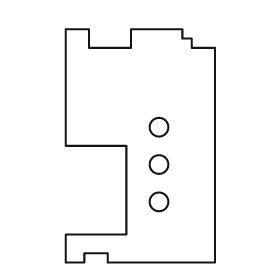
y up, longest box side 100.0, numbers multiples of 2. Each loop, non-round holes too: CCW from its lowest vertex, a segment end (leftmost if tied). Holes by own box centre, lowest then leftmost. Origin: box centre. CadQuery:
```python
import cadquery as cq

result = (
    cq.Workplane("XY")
    .moveTo(-32.0, -50.0)
    .lineTo(-24.0, -50.0)
    .lineTo(-24.0, -46.0)
    .lineTo(-14.0, -46.0)
    .lineTo(-14.0, -50.0)
    .lineTo(32.0, -50.0)
    .lineTo(32.0, 42.0)
    .lineTo(22.0, 42.0)
    .lineTo(22.0, 46.0)
    .lineTo(18.0, 46.0)
    .lineTo(18.0, 50.0)
    .lineTo(-4.0, 50.0)
    .lineTo(-4.0, 42.0)
    .lineTo(-22.0, 42.0)
    .lineTo(-22.0, 50.0)
    .lineTo(-32.0, 50.0)
    .lineTo(-32.0, 0.0)
    .lineTo(-6.0, 0.0)
    .lineTo(-6.0, -38.0)
    .lineTo(-32.0, -38.0)
    .close()
    .moveTo(8.0, -24.0)
    .circle(4.0)
    .moveTo(8.0, -8.0)
    .circle(4.0)
    .moveTo(8.0, 8.0)
    .circle(4.0)
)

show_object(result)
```